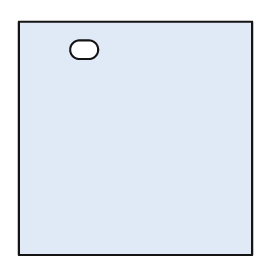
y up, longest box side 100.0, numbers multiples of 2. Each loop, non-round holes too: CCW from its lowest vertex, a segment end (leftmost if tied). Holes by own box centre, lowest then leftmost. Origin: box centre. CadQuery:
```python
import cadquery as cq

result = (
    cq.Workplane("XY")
    .moveTo(-50.0, -50.0)
    .lineTo(50.0, -50.0)
    .lineTo(50.0, 50.0)
    .lineTo(-50.0, 50.0)
    .close()
    .moveTo(-24.0, 34.0)
    .lineTo(-20.0, 34.0)
    .threePointArc((-16.0, 38.0), (-20.0, 42.0))
    .lineTo(-24.0, 42.0)
    .threePointArc((-28.0, 38.0), (-24.0, 34.0))
    .close()
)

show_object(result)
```